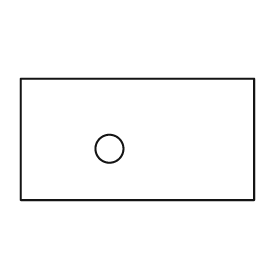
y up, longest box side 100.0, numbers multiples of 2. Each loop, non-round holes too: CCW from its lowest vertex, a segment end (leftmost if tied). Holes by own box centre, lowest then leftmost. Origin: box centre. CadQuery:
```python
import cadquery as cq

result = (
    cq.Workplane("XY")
    .moveTo(-50.0, -26.0)
    .lineTo(50.0, -26.0)
    .lineTo(50.0, 26.0)
    .lineTo(-50.0, 26.0)
    .close()
    .moveTo(-12.0, -4.0)
    .circle(6.0)
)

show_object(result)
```